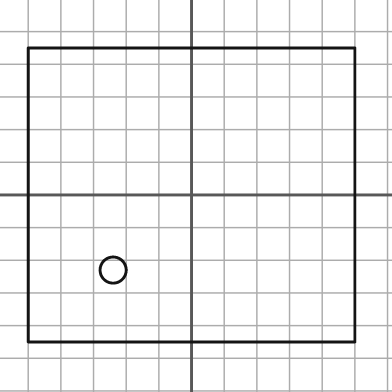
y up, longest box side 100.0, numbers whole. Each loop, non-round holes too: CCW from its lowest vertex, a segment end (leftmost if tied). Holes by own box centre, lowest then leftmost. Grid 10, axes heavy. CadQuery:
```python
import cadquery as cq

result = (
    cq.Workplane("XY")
    .moveTo(-50.0, -45.0)
    .lineTo(50.0, -45.0)
    .lineTo(50.0, 45.0)
    .lineTo(-50.0, 45.0)
    .close()
    .moveTo(-24.0, -23.0)
    .circle(4.0)
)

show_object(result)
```